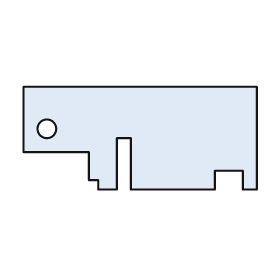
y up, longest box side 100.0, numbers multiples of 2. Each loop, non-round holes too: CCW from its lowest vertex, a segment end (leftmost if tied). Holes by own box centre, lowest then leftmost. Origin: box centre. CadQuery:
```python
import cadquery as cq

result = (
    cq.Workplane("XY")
    .moveTo(-18.0, -22.0)
    .lineTo(-10.0, -22.0)
    .lineTo(-10.0, 0.0)
    .lineTo(-4.0, 0.0)
    .lineTo(-4.0, -22.0)
    .lineTo(32.0, -22.0)
    .lineTo(32.0, -14.0)
    .lineTo(44.0, -14.0)
    .lineTo(44.0, -22.0)
    .lineTo(50.0, -22.0)
    .lineTo(50.0, 22.0)
    .lineTo(-50.0, 22.0)
    .lineTo(-50.0, -6.0)
    .lineTo(-22.0, -6.0)
    .lineTo(-22.0, -18.0)
    .lineTo(-18.0, -18.0)
    .close()
    .moveTo(-40.0, 4.0)
    .circle(4.0)
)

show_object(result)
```